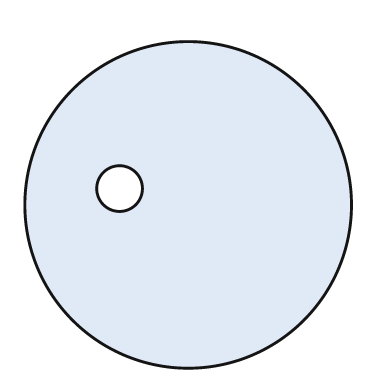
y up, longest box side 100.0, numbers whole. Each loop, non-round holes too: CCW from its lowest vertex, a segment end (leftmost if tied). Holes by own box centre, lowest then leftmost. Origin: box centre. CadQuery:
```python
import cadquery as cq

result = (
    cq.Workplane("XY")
    .moveTo(0.0, 0.0)
    .circle(50.0)
    .moveTo(-21.0, 5.0)
    .circle(7.0)
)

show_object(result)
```